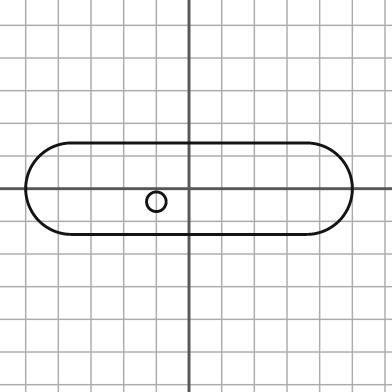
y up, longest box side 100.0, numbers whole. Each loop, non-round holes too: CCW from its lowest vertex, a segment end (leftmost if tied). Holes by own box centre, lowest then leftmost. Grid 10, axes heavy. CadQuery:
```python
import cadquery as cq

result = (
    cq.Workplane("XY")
    .moveTo(-36.0, -14.0)
    .lineTo(36.0, -14.0)
    .threePointArc((50.0, 0.0), (36.0, 14.0))
    .lineTo(-36.0, 14.0)
    .threePointArc((-50.0, 0.0), (-36.0, -14.0))
    .close()
    .moveTo(-10.0, -4.0)
    .circle(3.0)
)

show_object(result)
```